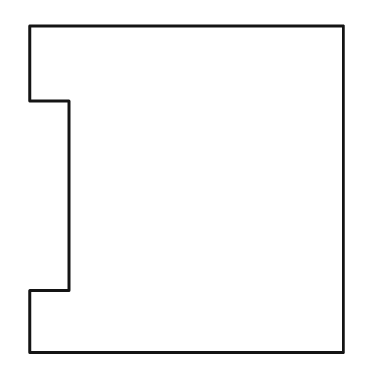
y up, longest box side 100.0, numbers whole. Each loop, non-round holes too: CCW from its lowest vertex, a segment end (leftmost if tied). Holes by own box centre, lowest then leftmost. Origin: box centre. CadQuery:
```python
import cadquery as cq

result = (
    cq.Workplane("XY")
    .moveTo(-48.0, -50.0)
    .lineTo(48.0, -50.0)
    .lineTo(48.0, 50.0)
    .lineTo(-48.0, 50.0)
    .lineTo(-48.0, 27.0)
    .lineTo(-36.0, 27.0)
    .lineTo(-36.0, -31.0)
    .lineTo(-48.0, -31.0)
    .close()
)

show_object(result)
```